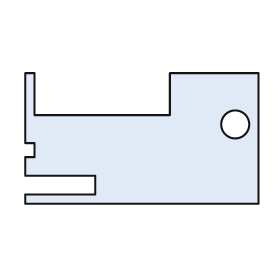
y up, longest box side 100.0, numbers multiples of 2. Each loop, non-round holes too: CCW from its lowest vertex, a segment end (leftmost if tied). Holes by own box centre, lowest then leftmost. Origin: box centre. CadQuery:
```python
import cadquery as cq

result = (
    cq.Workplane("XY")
    .moveTo(-50.0, -28.0)
    .lineTo(50.0, -28.0)
    .lineTo(50.0, 28.0)
    .lineTo(12.0, 28.0)
    .lineTo(12.0, 10.0)
    .lineTo(-46.0, 10.0)
    .lineTo(-46.0, 28.0)
    .lineTo(-50.0, 28.0)
    .lineTo(-50.0, -2.0)
    .lineTo(-46.0, -2.0)
    .lineTo(-46.0, -8.0)
    .lineTo(-50.0, -8.0)
    .lineTo(-50.0, -16.0)
    .lineTo(-20.0, -16.0)
    .lineTo(-20.0, -24.0)
    .lineTo(-50.0, -24.0)
    .close()
    .moveTo(40.0, 6.0)
    .circle(6.0)
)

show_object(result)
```